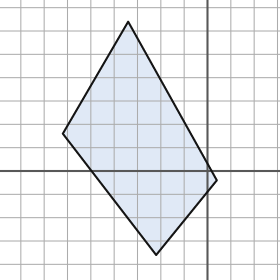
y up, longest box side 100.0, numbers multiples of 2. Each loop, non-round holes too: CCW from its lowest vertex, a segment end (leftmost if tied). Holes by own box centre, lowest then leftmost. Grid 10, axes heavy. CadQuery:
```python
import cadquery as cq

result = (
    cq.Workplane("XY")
    .moveTo(-22.0, -36.0)
    .lineTo(4.0, -4.0)
    .lineTo(-34.0, 64.0)
    .lineTo(-62.0, 16.0)
    .close()
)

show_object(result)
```